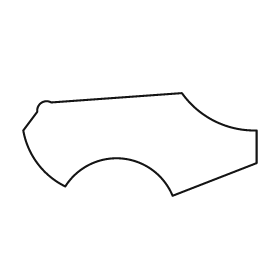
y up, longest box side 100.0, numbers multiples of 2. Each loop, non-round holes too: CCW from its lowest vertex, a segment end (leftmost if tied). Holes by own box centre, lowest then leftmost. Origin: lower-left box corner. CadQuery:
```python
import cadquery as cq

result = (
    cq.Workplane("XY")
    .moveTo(64.0, 0.0)
    .lineTo(100.0, 14.0)
    .lineTo(100.0, 28.0)
    .threePointArc((82.0, 32.0), (68.0, 44.0))
    .lineTo(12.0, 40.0)
    .threePointArc((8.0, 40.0), (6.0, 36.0))
    .lineTo(0.0, 28.0)
    .threePointArc((6.0, 14.0), (18.0, 4.0))
    .threePointArc((42.0, 16.0), (64.0, 0.0))
    .close()
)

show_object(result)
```